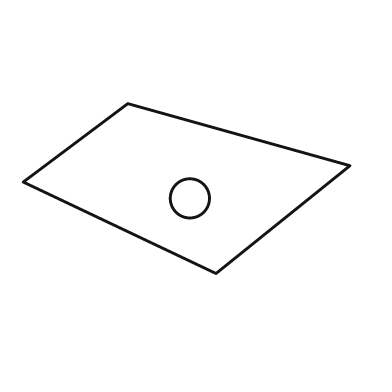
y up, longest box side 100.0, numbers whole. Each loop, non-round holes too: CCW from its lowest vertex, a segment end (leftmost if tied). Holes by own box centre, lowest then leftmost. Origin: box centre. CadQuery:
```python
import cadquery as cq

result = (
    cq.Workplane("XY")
    .moveTo(9.0, -26.0)
    .lineTo(50.0, 7.0)
    .lineTo(-18.0, 26.0)
    .lineTo(-50.0, 2.0)
    .close()
    .moveTo(1.0, -3.0)
    .circle(6.0)
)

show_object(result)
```